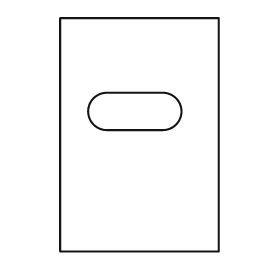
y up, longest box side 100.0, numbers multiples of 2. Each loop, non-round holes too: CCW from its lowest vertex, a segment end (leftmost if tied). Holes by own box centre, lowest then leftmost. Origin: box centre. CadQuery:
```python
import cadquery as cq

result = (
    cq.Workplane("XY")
    .moveTo(-34.0, -50.0)
    .lineTo(34.0, -50.0)
    .lineTo(34.0, 50.0)
    .lineTo(-34.0, 50.0)
    .close()
    .moveTo(-14.0, 2.0)
    .lineTo(10.0, 2.0)
    .threePointArc((18.0, 10.0), (10.0, 18.0))
    .lineTo(-14.0, 18.0)
    .threePointArc((-22.0, 10.0), (-14.0, 2.0))
    .close()
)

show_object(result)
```